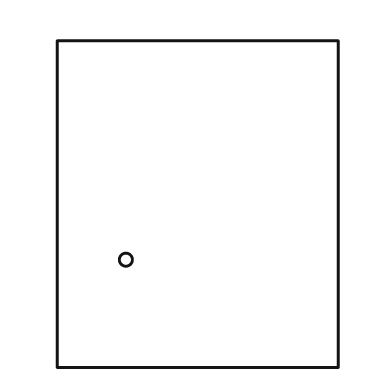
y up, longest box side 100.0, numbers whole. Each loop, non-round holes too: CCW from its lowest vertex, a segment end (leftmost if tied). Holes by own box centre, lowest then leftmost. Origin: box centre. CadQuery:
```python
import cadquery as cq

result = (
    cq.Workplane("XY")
    .moveTo(-43.0, -50.0)
    .lineTo(43.0, -50.0)
    .lineTo(43.0, 50.0)
    .lineTo(-43.0, 50.0)
    .close()
    .moveTo(-22.0, -17.0)
    .circle(2.0)
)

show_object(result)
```